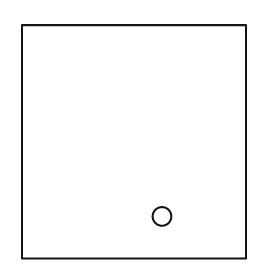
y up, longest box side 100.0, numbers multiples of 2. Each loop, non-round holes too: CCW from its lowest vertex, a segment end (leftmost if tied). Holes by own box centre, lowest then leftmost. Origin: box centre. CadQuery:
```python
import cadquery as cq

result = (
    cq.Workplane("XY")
    .moveTo(-48.0, -50.0)
    .lineTo(48.0, -50.0)
    .lineTo(48.0, 50.0)
    .lineTo(-48.0, 50.0)
    .close()
    .moveTo(12.0, -32.0)
    .circle(4.0)
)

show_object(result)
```